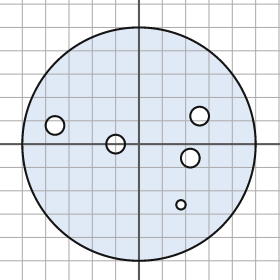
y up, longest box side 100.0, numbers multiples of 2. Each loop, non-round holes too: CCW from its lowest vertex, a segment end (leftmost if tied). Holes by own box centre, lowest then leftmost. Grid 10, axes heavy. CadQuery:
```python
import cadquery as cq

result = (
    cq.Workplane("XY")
    .moveTo(0.0, 0.0)
    .circle(50.0)
    .moveTo(18.0, -26.0)
    .circle(2.0)
    .moveTo(22.0, -6.0)
    .circle(4.0)
    .moveTo(-10.0, 0.0)
    .circle(4.0)
    .moveTo(-36.0, 8.0)
    .circle(4.0)
    .moveTo(26.0, 12.0)
    .circle(4.0)
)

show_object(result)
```